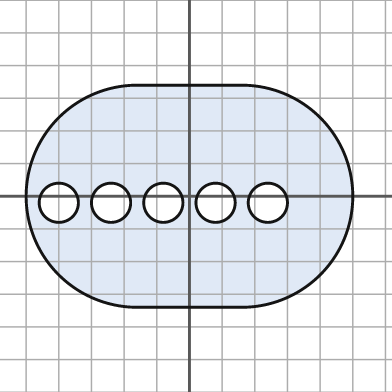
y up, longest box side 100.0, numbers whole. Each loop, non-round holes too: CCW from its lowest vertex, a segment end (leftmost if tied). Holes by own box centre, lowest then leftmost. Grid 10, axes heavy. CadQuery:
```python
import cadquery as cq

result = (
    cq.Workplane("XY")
    .moveTo(-16.0, -34.0)
    .lineTo(16.0, -34.0)
    .threePointArc((50.0, 0.0), (16.0, 34.0))
    .lineTo(-16.0, 34.0)
    .threePointArc((-50.0, 0.0), (-16.0, -34.0))
    .close()
    .moveTo(-40.0, -2.0)
    .circle(6.0)
    .moveTo(-24.0, -2.0)
    .circle(6.0)
    .moveTo(-8.0, -2.0)
    .circle(6.0)
    .moveTo(8.0, -2.0)
    .circle(6.0)
    .moveTo(24.0, -2.0)
    .circle(6.0)
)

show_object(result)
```